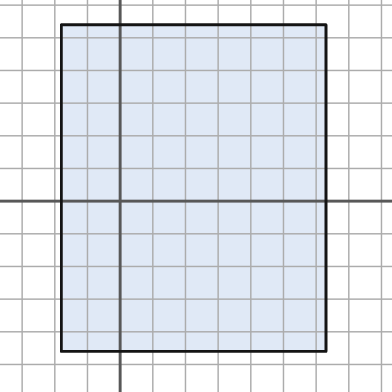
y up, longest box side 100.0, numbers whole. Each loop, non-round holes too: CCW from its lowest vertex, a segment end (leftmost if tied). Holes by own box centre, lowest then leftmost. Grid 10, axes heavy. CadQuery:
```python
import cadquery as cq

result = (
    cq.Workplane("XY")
    .moveTo(-18.0, -46.0)
    .lineTo(63.0, -46.0)
    .lineTo(63.0, 54.0)
    .lineTo(-18.0, 54.0)
    .close()
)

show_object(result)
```